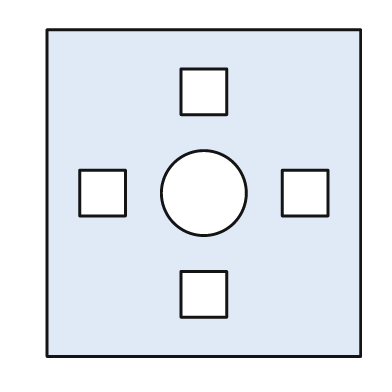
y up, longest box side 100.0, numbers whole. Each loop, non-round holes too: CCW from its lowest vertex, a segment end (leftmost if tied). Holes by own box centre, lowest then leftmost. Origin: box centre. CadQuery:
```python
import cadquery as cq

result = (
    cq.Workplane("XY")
    .moveTo(-48.0, -50.0)
    .lineTo(48.0, -50.0)
    .lineTo(48.0, 50.0)
    .lineTo(-48.0, 50.0)
    .close()
    .moveTo(-7.0, -38.0)
    .lineTo(7.0, -38.0)
    .lineTo(7.0, -24.0)
    .lineTo(-7.0, -24.0)
    .close()
    .moveTo(-38.0, -7.0)
    .lineTo(-24.0, -7.0)
    .lineTo(-24.0, 7.0)
    .lineTo(-38.0, 7.0)
    .close()
    .moveTo(0.0, 0.0)
    .circle(13.0)
    .moveTo(24.0, -7.0)
    .lineTo(38.0, -7.0)
    .lineTo(38.0, 7.0)
    .lineTo(24.0, 7.0)
    .close()
    .moveTo(-7.0, 24.0)
    .lineTo(7.0, 24.0)
    .lineTo(7.0, 38.0)
    .lineTo(-7.0, 38.0)
    .close()
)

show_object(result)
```